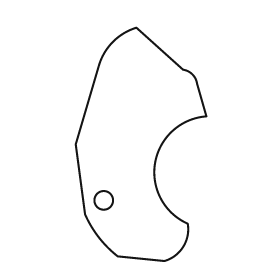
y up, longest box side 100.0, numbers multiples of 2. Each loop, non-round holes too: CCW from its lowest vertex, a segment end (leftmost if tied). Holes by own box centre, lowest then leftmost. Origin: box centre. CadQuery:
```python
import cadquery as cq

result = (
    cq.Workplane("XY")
    .moveTo(10.0, -50.0)
    .threePointArc((18.0, -44.0), (20.0, -34.0))
    .threePointArc((6.0, -8.0), (28.0, 12.0))
    .lineTo(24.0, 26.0)
    .threePointArc((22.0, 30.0), (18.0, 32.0))
    .lineTo(-2.0, 50.0)
    .threePointArc((-12.0, 44.0), (-18.0, 34.0))
    .lineTo(-28.0, 0.0)
    .lineTo(-24.0, -30.0)
    .threePointArc((-18.0, -40.0), (-10.0, -48.0))
    .close()
    .moveTo(-16.0, -24.0)
    .circle(4.0)
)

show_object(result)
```